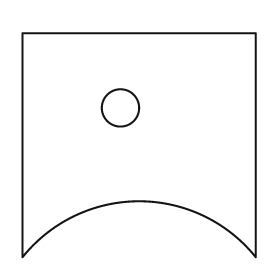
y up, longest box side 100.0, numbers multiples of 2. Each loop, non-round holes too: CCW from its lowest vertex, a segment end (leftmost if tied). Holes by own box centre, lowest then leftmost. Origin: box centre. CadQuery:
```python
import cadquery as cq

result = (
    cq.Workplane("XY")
    .moveTo(-50.0, -48.0)
    .threePointArc((0.0, -24.0), (50.0, -48.0))
    .lineTo(50.0, 48.0)
    .lineTo(-50.0, 48.0)
    .close()
    .moveTo(-8.0, 16.0)
    .circle(8.0)
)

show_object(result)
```